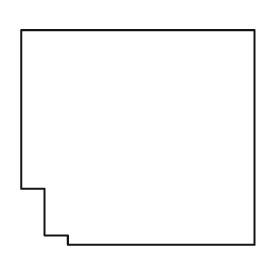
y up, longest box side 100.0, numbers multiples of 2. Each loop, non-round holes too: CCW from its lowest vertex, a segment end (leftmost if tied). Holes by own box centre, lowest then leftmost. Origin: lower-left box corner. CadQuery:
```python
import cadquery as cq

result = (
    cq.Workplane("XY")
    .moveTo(20.0, 0.0)
    .lineTo(100.0, 0.0)
    .lineTo(100.0, 92.0)
    .lineTo(0.0, 92.0)
    .lineTo(0.0, 24.0)
    .lineTo(10.0, 24.0)
    .lineTo(10.0, 4.0)
    .lineTo(20.0, 4.0)
    .close()
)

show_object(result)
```